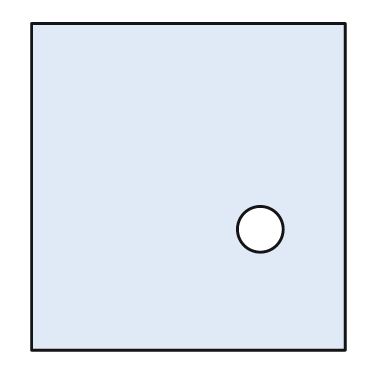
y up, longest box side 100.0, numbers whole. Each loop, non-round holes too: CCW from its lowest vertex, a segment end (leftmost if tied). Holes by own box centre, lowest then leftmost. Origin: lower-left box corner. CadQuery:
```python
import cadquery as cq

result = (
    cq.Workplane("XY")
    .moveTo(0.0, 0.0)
    .lineTo(96.0, 0.0)
    .lineTo(96.0, 100.0)
    .lineTo(0.0, 100.0)
    .close()
    .moveTo(70.0, 37.0)
    .circle(7.0)
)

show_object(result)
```